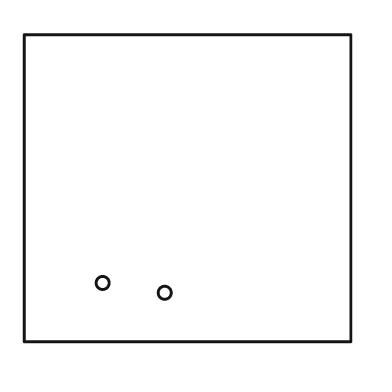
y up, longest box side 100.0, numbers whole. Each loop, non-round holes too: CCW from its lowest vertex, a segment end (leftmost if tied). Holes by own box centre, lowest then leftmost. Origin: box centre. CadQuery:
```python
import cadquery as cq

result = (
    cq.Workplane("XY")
    .moveTo(-50.0, -47.0)
    .lineTo(50.0, -47.0)
    .lineTo(50.0, 47.0)
    .lineTo(-50.0, 47.0)
    .close()
    .moveTo(-7.0, -32.0)
    .circle(2.0)
    .moveTo(-26.0, -29.0)
    .circle(2.0)
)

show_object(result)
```